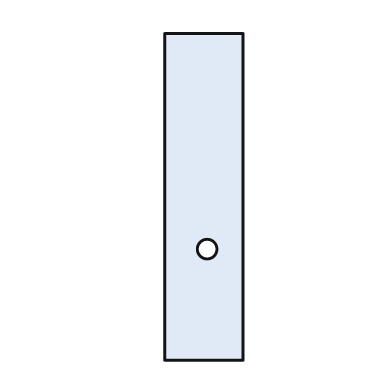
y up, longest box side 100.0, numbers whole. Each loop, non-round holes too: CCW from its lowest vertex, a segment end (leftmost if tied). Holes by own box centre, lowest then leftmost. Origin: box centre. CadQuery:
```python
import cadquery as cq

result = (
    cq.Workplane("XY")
    .moveTo(-12.0, -50.0)
    .lineTo(12.0, -50.0)
    .lineTo(12.0, 50.0)
    .lineTo(-12.0, 50.0)
    .close()
    .moveTo(1.0, -16.0)
    .circle(3.0)
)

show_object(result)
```